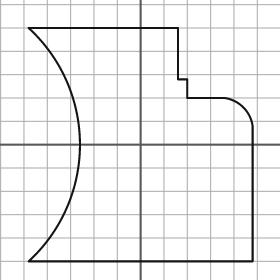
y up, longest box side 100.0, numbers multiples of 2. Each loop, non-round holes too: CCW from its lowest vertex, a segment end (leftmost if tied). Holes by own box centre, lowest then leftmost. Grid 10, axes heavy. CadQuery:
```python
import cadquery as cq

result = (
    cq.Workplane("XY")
    .moveTo(-48.0, -50.0)
    .lineTo(48.0, -50.0)
    .lineTo(48.0, 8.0)
    .threePointArc((44.0, 16.0), (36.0, 20.0))
    .lineTo(20.0, 20.0)
    .lineTo(20.0, 28.0)
    .lineTo(16.0, 28.0)
    .lineTo(16.0, 50.0)
    .lineTo(-48.0, 50.0)
    .threePointArc((-26.0, 0.0), (-48.0, -50.0))
    .close()
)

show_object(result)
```